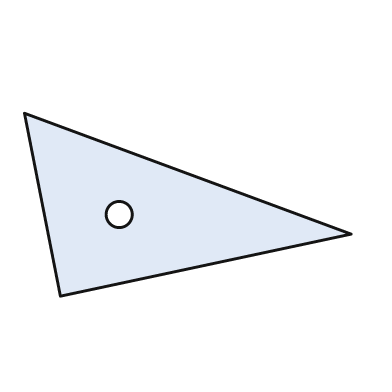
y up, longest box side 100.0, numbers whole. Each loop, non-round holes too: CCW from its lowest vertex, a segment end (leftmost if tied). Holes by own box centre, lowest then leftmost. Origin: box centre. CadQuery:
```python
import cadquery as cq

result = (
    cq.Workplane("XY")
    .moveTo(-39.0, -28.0)
    .lineTo(50.0, -9.0)
    .lineTo(-50.0, 28.0)
    .close()
    .moveTo(-21.0, -3.0)
    .circle(4.0)
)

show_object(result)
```